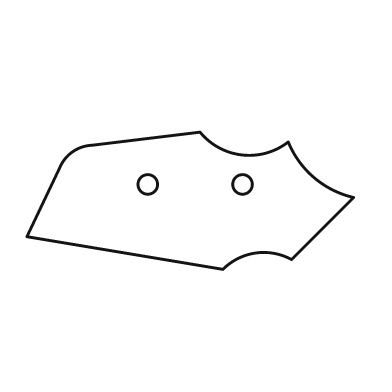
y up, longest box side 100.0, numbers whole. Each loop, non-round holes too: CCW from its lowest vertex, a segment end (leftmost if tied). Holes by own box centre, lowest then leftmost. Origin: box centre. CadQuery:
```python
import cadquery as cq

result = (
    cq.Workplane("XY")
    .moveTo(10.0, -21.0)
    .threePointArc((20.0, -16.0), (31.0, -18.0))
    .lineTo(50.0, 1.0)
    .threePointArc((38.0, 7.0), (30.0, 18.0))
    .threePointArc((16.0, 14.0), (3.0, 21.0))
    .lineTo(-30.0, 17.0)
    .threePointArc((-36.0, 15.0), (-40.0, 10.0))
    .lineTo(-50.0, -11.0)
    .close()
    .moveTo(-13.0, 5.0)
    .circle(3.0)
    .moveTo(16.0, 5.0)
    .circle(3.0)
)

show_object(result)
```